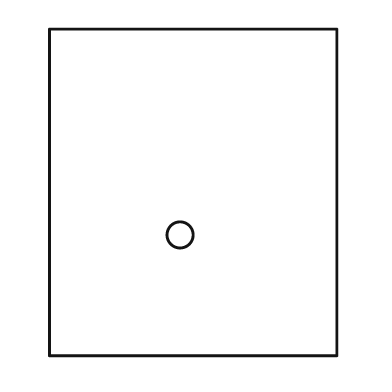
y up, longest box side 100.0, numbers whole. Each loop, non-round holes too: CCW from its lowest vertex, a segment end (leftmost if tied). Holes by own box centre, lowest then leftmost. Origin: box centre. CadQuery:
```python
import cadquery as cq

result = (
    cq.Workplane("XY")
    .moveTo(-44.0, -50.0)
    .lineTo(44.0, -50.0)
    .lineTo(44.0, 50.0)
    .lineTo(-44.0, 50.0)
    .close()
    .moveTo(-4.0, -13.0)
    .circle(4.0)
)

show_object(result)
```